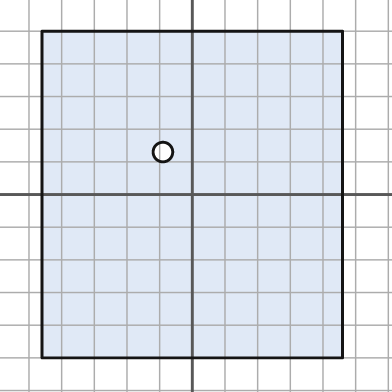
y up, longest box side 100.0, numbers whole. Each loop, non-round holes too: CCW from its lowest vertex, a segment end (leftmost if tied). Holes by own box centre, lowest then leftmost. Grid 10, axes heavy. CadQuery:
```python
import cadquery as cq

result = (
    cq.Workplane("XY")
    .moveTo(-46.0, -50.0)
    .lineTo(46.0, -50.0)
    .lineTo(46.0, 50.0)
    .lineTo(-46.0, 50.0)
    .close()
    .moveTo(-9.0, 13.0)
    .circle(3.0)
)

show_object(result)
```